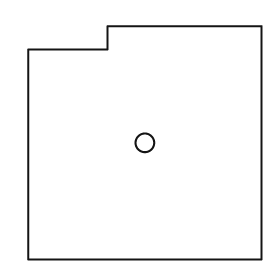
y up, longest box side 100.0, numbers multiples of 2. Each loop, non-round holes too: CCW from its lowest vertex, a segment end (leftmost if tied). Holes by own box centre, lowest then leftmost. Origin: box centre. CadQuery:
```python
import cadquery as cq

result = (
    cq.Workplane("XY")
    .moveTo(-50.0, -50.0)
    .lineTo(50.0, -50.0)
    .lineTo(50.0, 50.0)
    .lineTo(-16.0, 50.0)
    .lineTo(-16.0, 40.0)
    .lineTo(-50.0, 40.0)
    .close()
    .moveTo(0.0, 0.0)
    .circle(4.0)
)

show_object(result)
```